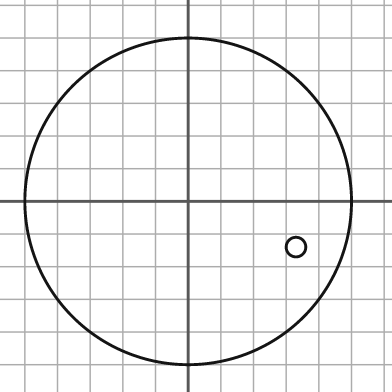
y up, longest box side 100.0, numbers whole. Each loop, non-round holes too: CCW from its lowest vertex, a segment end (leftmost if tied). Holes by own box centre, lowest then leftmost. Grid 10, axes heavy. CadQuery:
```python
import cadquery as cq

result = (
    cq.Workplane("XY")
    .moveTo(0.0, 0.0)
    .circle(50.0)
    .moveTo(33.0, -14.0)
    .circle(3.0)
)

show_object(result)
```